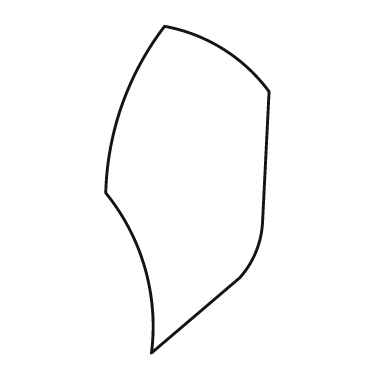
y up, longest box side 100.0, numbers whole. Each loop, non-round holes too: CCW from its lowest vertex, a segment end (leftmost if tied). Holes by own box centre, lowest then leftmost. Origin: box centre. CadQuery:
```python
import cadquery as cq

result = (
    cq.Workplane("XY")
    .moveTo(-11.0, -50.0)
    .lineTo(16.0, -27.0)
    .threePointArc((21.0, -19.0), (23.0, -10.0))
    .lineTo(25.0, 30.0)
    .threePointArc((11.0, 43.0), (-7.0, 50.0))
    .threePointArc((-20.0, 26.0), (-25.0, -1.0))
    .threePointArc((-13.0, -24.0), (-11.0, -50.0))
    .close()
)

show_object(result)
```